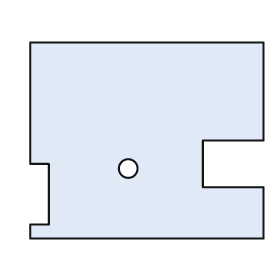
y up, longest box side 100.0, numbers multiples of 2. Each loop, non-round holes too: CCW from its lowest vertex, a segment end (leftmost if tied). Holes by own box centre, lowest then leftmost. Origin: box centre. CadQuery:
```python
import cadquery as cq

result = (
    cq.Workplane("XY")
    .moveTo(-50.0, -42.0)
    .lineTo(50.0, -42.0)
    .lineTo(50.0, -20.0)
    .lineTo(24.0, -20.0)
    .lineTo(24.0, 0.0)
    .lineTo(50.0, 0.0)
    .lineTo(50.0, 42.0)
    .lineTo(-50.0, 42.0)
    .lineTo(-50.0, -10.0)
    .lineTo(-42.0, -10.0)
    .lineTo(-42.0, -36.0)
    .lineTo(-50.0, -36.0)
    .close()
    .moveTo(-8.0, -12.0)
    .circle(4.0)
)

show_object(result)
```